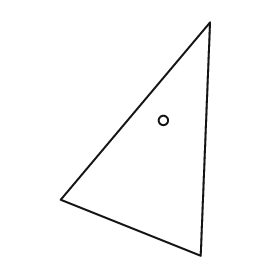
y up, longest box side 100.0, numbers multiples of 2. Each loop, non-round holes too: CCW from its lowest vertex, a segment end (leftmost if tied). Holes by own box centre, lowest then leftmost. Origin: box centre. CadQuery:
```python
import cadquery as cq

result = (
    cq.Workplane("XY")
    .moveTo(28.0, -50.0)
    .lineTo(32.0, 50.0)
    .lineTo(-32.0, -26.0)
    .close()
    .moveTo(12.0, 8.0)
    .circle(2.0)
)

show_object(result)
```